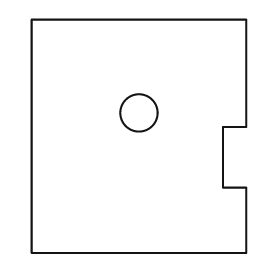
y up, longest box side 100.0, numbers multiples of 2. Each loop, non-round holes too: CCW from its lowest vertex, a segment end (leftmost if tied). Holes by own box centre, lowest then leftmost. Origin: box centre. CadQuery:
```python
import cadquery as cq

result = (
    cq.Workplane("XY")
    .moveTo(-46.0, -50.0)
    .lineTo(46.0, -50.0)
    .lineTo(46.0, -22.0)
    .lineTo(36.0, -22.0)
    .lineTo(36.0, 4.0)
    .lineTo(46.0, 4.0)
    .lineTo(46.0, 50.0)
    .lineTo(-46.0, 50.0)
    .close()
    .moveTo(0.0, 10.0)
    .circle(8.0)
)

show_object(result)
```